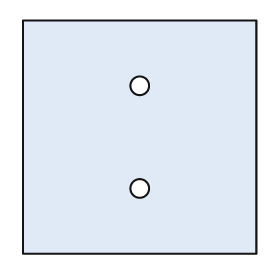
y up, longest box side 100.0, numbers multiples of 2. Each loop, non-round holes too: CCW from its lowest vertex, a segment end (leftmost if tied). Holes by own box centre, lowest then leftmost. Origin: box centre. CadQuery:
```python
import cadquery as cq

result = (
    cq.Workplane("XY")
    .moveTo(-50.0, -50.0)
    .lineTo(50.0, -50.0)
    .lineTo(50.0, 50.0)
    .lineTo(-50.0, 50.0)
    .close()
    .moveTo(0.0, -22.0)
    .circle(4.0)
    .moveTo(0.0, 22.0)
    .circle(4.0)
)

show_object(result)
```